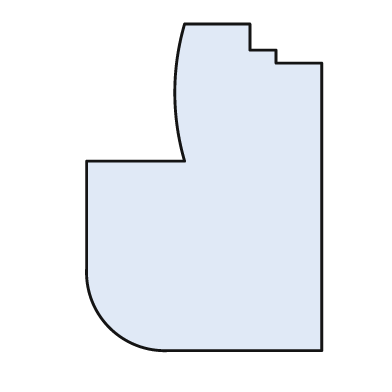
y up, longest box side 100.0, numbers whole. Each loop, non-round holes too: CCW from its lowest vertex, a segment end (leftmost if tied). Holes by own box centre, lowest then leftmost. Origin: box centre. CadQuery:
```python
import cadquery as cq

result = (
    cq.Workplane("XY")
    .moveTo(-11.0, -50.0)
    .lineTo(36.0, -50.0)
    .lineTo(36.0, 38.0)
    .lineTo(22.0, 38.0)
    .lineTo(22.0, 42.0)
    .lineTo(14.0, 42.0)
    .lineTo(14.0, 50.0)
    .lineTo(-6.0, 50.0)
    .threePointArc((-9.0, 29.0), (-6.0, 8.0))
    .lineTo(-36.0, 8.0)
    .lineTo(-36.0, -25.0)
    .threePointArc((-29.0, -43.0), (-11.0, -50.0))
    .close()
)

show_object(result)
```